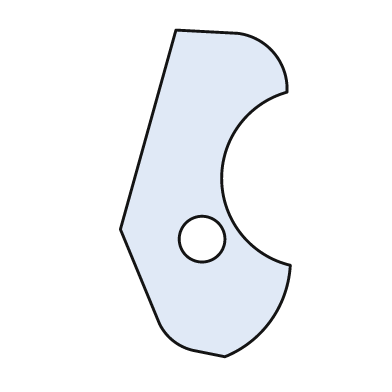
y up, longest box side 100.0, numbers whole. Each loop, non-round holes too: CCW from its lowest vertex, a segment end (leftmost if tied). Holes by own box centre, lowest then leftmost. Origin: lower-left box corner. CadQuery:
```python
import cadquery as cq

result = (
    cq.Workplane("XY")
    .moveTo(32.0, 0.0)
    .threePointArc((46.0, 11.0), (52.0, 28.0))
    .threePointArc((31.0, 54.0), (51.0, 81.0))
    .threePointArc((47.0, 93.0), (36.0, 99.0))
    .lineTo(17.0, 100.0)
    .lineTo(0.0, 39.0)
    .lineTo(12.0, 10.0)
    .threePointArc((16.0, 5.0), (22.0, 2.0))
    .close()
    .moveTo(25.0, 36.0)
    .circle(7.0)
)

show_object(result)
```